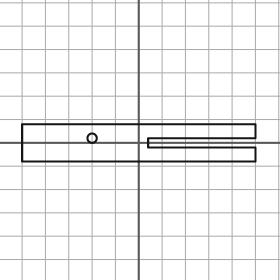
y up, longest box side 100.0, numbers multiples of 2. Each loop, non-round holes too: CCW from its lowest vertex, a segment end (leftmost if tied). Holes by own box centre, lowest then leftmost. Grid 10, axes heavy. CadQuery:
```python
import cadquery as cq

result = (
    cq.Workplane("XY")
    .moveTo(-50.0, -8.0)
    .lineTo(50.0, -8.0)
    .lineTo(50.0, -2.0)
    .lineTo(4.0, -2.0)
    .lineTo(4.0, 2.0)
    .lineTo(50.0, 2.0)
    .lineTo(50.0, 8.0)
    .lineTo(-50.0, 8.0)
    .close()
    .moveTo(-20.0, 2.0)
    .circle(2.0)
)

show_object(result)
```